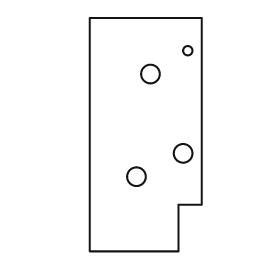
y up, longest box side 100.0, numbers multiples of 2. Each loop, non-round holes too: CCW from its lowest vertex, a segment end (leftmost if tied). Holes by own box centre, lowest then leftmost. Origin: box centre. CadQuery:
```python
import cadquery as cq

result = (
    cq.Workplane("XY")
    .moveTo(-24.0, -50.0)
    .lineTo(14.0, -50.0)
    .lineTo(14.0, -30.0)
    .lineTo(24.0, -30.0)
    .lineTo(24.0, 50.0)
    .lineTo(-24.0, 50.0)
    .close()
    .moveTo(-4.0, -18.0)
    .circle(4.0)
    .moveTo(16.0, -8.0)
    .circle(4.0)
    .moveTo(2.0, 26.0)
    .circle(4.0)
    .moveTo(18.0, 36.0)
    .circle(2.0)
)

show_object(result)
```